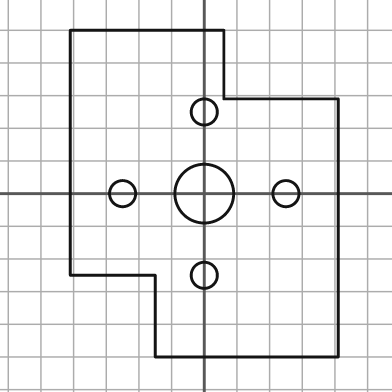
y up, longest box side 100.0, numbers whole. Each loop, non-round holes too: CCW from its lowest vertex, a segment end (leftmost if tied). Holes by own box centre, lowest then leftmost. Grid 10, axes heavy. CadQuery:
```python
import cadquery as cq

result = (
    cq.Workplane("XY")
    .moveTo(-15.0, -50.0)
    .lineTo(41.0, -50.0)
    .lineTo(41.0, 29.0)
    .lineTo(6.0, 29.0)
    .lineTo(6.0, 50.0)
    .lineTo(-41.0, 50.0)
    .lineTo(-41.0, -25.0)
    .lineTo(-15.0, -25.0)
    .close()
    .moveTo(0.0, -25.0)
    .circle(4.0)
    .moveTo(-25.0, 0.0)
    .circle(4.0)
    .moveTo(0.0, 0.0)
    .circle(9.0)
    .moveTo(25.0, 0.0)
    .circle(4.0)
    .moveTo(0.0, 25.0)
    .circle(4.0)
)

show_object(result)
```